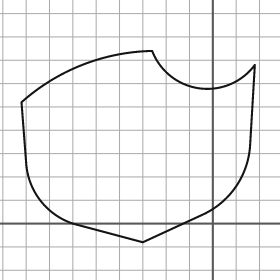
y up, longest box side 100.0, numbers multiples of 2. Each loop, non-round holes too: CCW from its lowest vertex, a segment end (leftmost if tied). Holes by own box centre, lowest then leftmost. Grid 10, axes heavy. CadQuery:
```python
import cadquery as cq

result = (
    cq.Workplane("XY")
    .moveTo(-30.0, -8.0)
    .lineTo(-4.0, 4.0)
    .threePointArc((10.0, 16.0), (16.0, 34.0))
    .lineTo(18.0, 68.0)
    .threePointArc((-6.0, 58.0), (-26.0, 74.0))
    .threePointArc((-56.0, 68.0), (-82.0, 52.0))
    .lineTo(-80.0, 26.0)
    .threePointArc((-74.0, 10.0), (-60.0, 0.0))
    .close()
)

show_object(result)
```